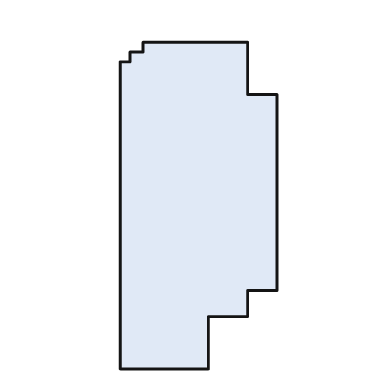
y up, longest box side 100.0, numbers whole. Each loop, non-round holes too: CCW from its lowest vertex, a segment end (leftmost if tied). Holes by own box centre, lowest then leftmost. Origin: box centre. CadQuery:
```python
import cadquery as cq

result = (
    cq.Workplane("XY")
    .moveTo(-24.0, -50.0)
    .lineTo(3.0, -50.0)
    .lineTo(3.0, -34.0)
    .lineTo(15.0, -34.0)
    .lineTo(15.0, -26.0)
    .lineTo(24.0, -26.0)
    .lineTo(24.0, 34.0)
    .lineTo(15.0, 34.0)
    .lineTo(15.0, 50.0)
    .lineTo(-17.0, 50.0)
    .lineTo(-17.0, 47.0)
    .lineTo(-21.0, 47.0)
    .lineTo(-21.0, 44.0)
    .lineTo(-24.0, 44.0)
    .close()
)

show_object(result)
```